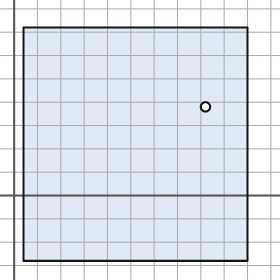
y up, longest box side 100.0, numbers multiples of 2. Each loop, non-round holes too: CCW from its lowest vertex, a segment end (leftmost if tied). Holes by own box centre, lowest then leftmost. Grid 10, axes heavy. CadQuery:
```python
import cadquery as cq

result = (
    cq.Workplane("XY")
    .moveTo(4.0, -28.0)
    .lineTo(100.0, -28.0)
    .lineTo(100.0, 72.0)
    .lineTo(4.0, 72.0)
    .close()
    .moveTo(82.0, 38.0)
    .circle(2.0)
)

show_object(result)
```